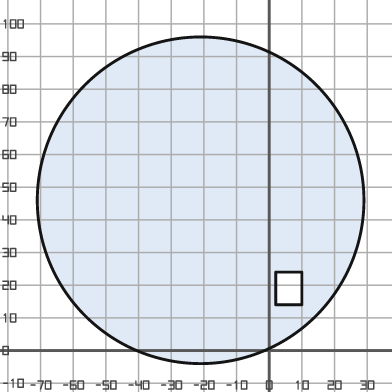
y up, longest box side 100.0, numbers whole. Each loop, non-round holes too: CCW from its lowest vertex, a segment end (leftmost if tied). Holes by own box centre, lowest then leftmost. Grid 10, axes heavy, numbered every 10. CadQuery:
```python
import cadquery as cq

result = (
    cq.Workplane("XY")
    .moveTo(-21.0, 46.0)
    .circle(50.0)
    .moveTo(2.0, 14.0)
    .lineTo(10.0, 14.0)
    .lineTo(10.0, 24.0)
    .lineTo(2.0, 24.0)
    .close()
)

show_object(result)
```